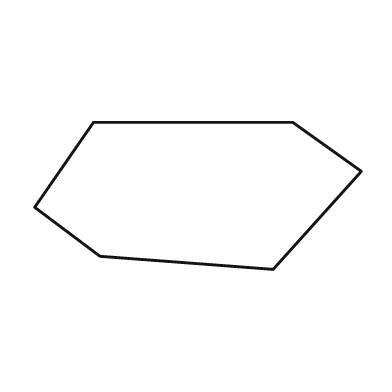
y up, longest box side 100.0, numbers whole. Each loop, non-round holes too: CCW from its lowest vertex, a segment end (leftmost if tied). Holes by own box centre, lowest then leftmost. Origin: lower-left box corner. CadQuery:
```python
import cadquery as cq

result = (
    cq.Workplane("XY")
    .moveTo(73.0, 0.0)
    .lineTo(100.0, 30.0)
    .lineTo(79.0, 45.0)
    .lineTo(18.0, 45.0)
    .lineTo(0.0, 19.0)
    .lineTo(20.0, 4.0)
    .close()
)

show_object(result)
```